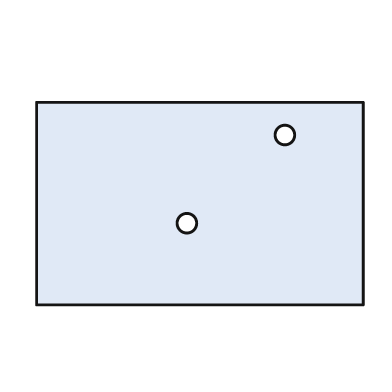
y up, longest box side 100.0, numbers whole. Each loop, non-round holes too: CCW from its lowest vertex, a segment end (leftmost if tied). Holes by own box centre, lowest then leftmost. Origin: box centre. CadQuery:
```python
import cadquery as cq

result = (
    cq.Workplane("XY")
    .moveTo(-50.0, -31.0)
    .lineTo(50.0, -31.0)
    .lineTo(50.0, 31.0)
    .lineTo(-50.0, 31.0)
    .close()
    .moveTo(-4.0, -6.0)
    .circle(3.0)
    .moveTo(26.0, 21.0)
    .circle(3.0)
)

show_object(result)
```